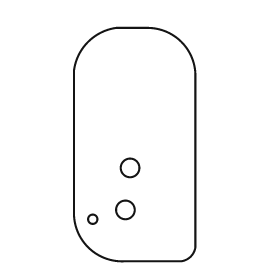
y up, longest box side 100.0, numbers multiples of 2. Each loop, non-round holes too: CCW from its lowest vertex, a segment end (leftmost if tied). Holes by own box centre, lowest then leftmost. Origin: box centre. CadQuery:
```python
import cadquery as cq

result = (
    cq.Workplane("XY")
    .moveTo(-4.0, -50.0)
    .lineTo(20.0, -50.0)
    .threePointArc((24.0, -48.0), (26.0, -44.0))
    .lineTo(26.0, 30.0)
    .threePointArc((20.0, 44.0), (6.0, 50.0))
    .lineTo(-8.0, 50.0)
    .threePointArc((-20.0, 44.0), (-26.0, 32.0))
    .lineTo(-26.0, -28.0)
    .threePointArc((-20.0, -44.0), (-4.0, -50.0))
    .close()
    .moveTo(-18.0, -32.0)
    .circle(2.0)
    .moveTo(-4.0, -28.0)
    .circle(4.0)
    .moveTo(-2.0, -10.0)
    .circle(4.0)
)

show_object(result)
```